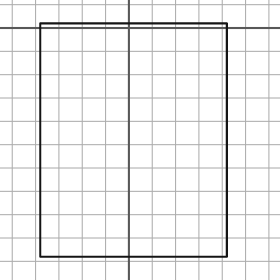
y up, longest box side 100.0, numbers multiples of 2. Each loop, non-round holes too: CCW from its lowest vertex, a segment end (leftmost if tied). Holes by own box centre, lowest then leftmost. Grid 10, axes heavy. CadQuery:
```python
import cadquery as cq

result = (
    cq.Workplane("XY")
    .moveTo(-38.0, -98.0)
    .lineTo(42.0, -98.0)
    .lineTo(42.0, 2.0)
    .lineTo(-38.0, 2.0)
    .close()
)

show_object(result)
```